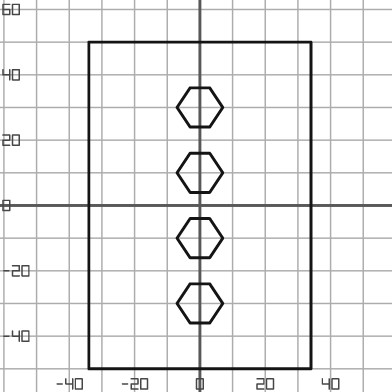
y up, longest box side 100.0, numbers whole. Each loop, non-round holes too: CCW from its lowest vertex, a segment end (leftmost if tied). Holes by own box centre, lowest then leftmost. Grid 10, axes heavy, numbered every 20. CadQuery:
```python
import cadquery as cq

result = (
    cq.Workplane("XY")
    .moveTo(-34.0, -50.0)
    .lineTo(34.0, -50.0)
    .lineTo(34.0, 50.0)
    .lineTo(-34.0, 50.0)
    .close()
    .moveTo(-3.0, -36.0)
    .lineTo(3.0, -36.0)
    .lineTo(7.0, -30.0)
    .lineTo(3.0, -24.0)
    .lineTo(-3.0, -24.0)
    .lineTo(-7.0, -30.0)
    .close()
    .moveTo(-3.0, -16.0)
    .lineTo(3.0, -16.0)
    .lineTo(7.0, -10.0)
    .lineTo(3.0, -4.0)
    .lineTo(-3.0, -4.0)
    .lineTo(-7.0, -10.0)
    .close()
    .moveTo(-3.0, 4.0)
    .lineTo(3.0, 4.0)
    .lineTo(7.0, 10.0)
    .lineTo(3.0, 16.0)
    .lineTo(-3.0, 16.0)
    .lineTo(-7.0, 10.0)
    .close()
    .moveTo(-3.0, 24.0)
    .lineTo(3.0, 24.0)
    .lineTo(7.0, 30.0)
    .lineTo(3.0, 36.0)
    .lineTo(-3.0, 36.0)
    .lineTo(-7.0, 30.0)
    .close()
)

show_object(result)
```